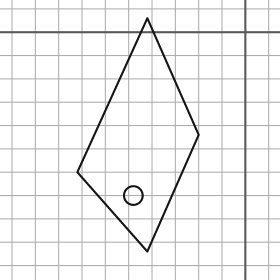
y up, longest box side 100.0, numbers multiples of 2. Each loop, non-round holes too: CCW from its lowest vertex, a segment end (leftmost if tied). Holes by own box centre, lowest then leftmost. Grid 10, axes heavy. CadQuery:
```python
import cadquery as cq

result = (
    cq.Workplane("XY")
    .moveTo(-42.0, -94.0)
    .lineTo(-20.0, -44.0)
    .lineTo(-42.0, 6.0)
    .lineTo(-72.0, -60.0)
    .close()
    .moveTo(-48.0, -70.0)
    .circle(4.0)
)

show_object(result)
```